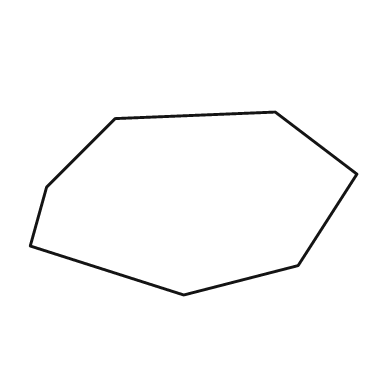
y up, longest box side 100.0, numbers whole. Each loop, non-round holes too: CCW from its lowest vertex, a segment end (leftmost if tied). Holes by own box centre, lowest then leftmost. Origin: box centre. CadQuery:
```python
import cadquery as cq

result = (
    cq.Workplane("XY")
    .moveTo(-3.0, -28.0)
    .lineTo(32.0, -19.0)
    .lineTo(50.0, 9.0)
    .lineTo(25.0, 28.0)
    .lineTo(-24.0, 26.0)
    .lineTo(-45.0, 5.0)
    .lineTo(-50.0, -13.0)
    .close()
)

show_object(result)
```